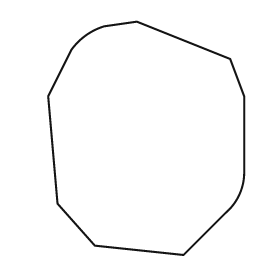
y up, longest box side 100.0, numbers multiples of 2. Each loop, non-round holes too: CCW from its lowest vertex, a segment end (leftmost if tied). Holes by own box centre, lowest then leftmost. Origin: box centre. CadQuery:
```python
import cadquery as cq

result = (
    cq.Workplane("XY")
    .moveTo(16.0, -50.0)
    .lineTo(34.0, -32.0)
    .threePointArc((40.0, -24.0), (42.0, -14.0))
    .lineTo(42.0, 18.0)
    .lineTo(36.0, 34.0)
    .lineTo(-4.0, 50.0)
    .lineTo(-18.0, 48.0)
    .threePointArc((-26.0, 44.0), (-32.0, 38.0))
    .lineTo(-42.0, 18.0)
    .lineTo(-38.0, -28.0)
    .lineTo(-22.0, -46.0)
    .close()
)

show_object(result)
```